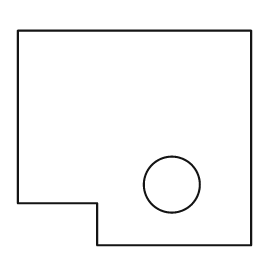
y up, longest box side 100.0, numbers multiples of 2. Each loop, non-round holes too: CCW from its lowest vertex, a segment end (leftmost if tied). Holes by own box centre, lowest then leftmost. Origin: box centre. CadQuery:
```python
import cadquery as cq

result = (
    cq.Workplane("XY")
    .moveTo(-16.0, -46.0)
    .lineTo(50.0, -46.0)
    .lineTo(50.0, 46.0)
    .lineTo(-50.0, 46.0)
    .lineTo(-50.0, -28.0)
    .lineTo(-16.0, -28.0)
    .close()
    .moveTo(16.0, -20.0)
    .circle(12.0)
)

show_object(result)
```